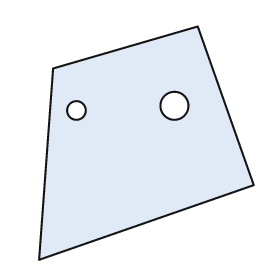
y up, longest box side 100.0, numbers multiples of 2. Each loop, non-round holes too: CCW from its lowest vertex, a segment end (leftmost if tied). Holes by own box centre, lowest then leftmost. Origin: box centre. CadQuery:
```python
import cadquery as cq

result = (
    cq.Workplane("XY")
    .moveTo(-46.0, -50.0)
    .lineTo(46.0, -18.0)
    .lineTo(22.0, 50.0)
    .lineTo(-40.0, 32.0)
    .close()
    .moveTo(-30.0, 14.0)
    .circle(4.0)
    .moveTo(12.0, 16.0)
    .circle(6.0)
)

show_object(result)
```